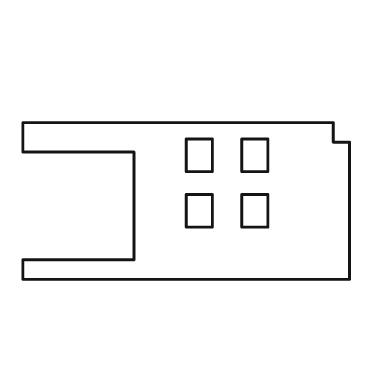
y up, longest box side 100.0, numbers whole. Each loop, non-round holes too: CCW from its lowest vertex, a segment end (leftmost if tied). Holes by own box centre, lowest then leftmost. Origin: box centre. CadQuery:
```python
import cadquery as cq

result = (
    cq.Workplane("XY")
    .moveTo(-50.0, -24.0)
    .lineTo(50.0, -24.0)
    .lineTo(50.0, 18.0)
    .lineTo(45.0, 18.0)
    .lineTo(45.0, 24.0)
    .lineTo(-50.0, 24.0)
    .lineTo(-50.0, 15.0)
    .lineTo(-16.0, 15.0)
    .lineTo(-16.0, -18.0)
    .lineTo(-50.0, -18.0)
    .close()
    .moveTo(0.0, -8.0)
    .lineTo(8.0, -8.0)
    .lineTo(8.0, 2.0)
    .lineTo(0.0, 2.0)
    .close()
    .moveTo(17.0, -8.0)
    .lineTo(25.0, -8.0)
    .lineTo(25.0, 2.0)
    .lineTo(17.0, 2.0)
    .close()
    .moveTo(0.0, 9.0)
    .lineTo(8.0, 9.0)
    .lineTo(8.0, 19.0)
    .lineTo(0.0, 19.0)
    .close()
    .moveTo(17.0, 9.0)
    .lineTo(25.0, 9.0)
    .lineTo(25.0, 19.0)
    .lineTo(17.0, 19.0)
    .close()
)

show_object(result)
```